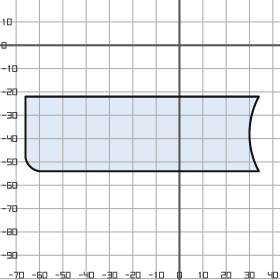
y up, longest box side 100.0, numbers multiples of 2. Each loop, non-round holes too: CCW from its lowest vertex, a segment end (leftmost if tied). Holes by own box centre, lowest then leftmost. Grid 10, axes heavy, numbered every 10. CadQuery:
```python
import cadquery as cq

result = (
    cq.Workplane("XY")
    .moveTo(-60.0, -54.0)
    .lineTo(34.0, -54.0)
    .threePointArc((30.0, -38.0), (34.0, -22.0))
    .lineTo(-66.0, -22.0)
    .lineTo(-66.0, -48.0)
    .threePointArc((-64.0, -52.0), (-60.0, -54.0))
    .close()
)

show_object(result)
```